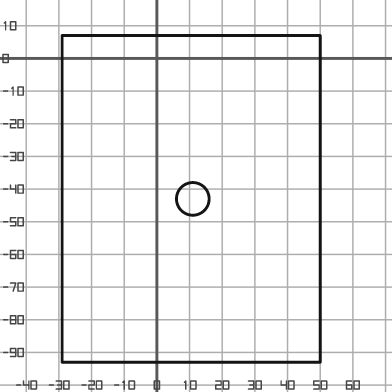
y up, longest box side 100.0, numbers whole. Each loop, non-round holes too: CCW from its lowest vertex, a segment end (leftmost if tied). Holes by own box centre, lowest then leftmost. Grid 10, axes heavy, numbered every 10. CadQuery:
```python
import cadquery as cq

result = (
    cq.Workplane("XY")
    .moveTo(-29.0, -93.0)
    .lineTo(50.0, -93.0)
    .lineTo(50.0, 7.0)
    .lineTo(-29.0, 7.0)
    .close()
    .moveTo(11.0, -43.0)
    .circle(5.0)
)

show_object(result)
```